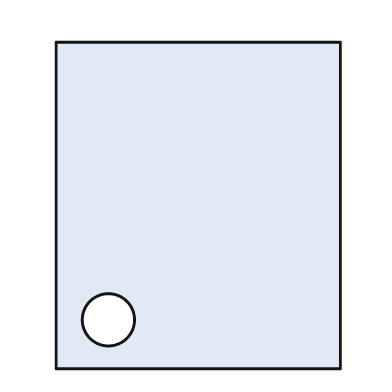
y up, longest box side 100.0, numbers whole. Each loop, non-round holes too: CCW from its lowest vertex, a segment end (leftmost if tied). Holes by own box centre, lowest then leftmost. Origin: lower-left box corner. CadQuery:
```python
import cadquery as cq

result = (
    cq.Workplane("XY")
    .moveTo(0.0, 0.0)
    .lineTo(87.0, 0.0)
    .lineTo(87.0, 100.0)
    .lineTo(0.0, 100.0)
    .close()
    .moveTo(16.0, 15.0)
    .circle(8.0)
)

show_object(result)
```